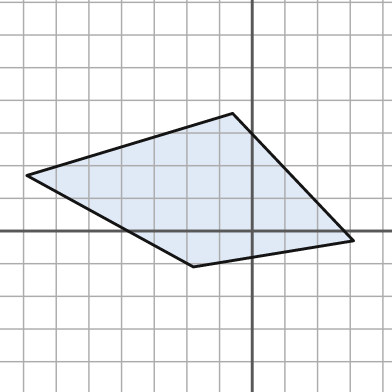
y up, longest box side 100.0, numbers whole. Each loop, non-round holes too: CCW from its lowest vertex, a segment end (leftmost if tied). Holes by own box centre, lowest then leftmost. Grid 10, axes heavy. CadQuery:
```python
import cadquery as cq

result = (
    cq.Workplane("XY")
    .moveTo(-18.0, -11.0)
    .lineTo(31.0, -3.0)
    .lineTo(-6.0, 36.0)
    .lineTo(-69.0, 17.0)
    .close()
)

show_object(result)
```